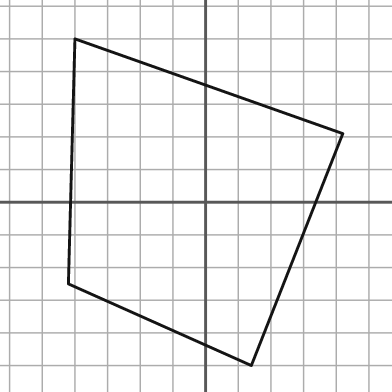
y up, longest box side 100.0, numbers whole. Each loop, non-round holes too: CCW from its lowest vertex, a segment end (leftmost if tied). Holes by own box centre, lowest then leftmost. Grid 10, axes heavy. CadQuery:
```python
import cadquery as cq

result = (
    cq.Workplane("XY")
    .moveTo(14.0, -50.0)
    .lineTo(42.0, 21.0)
    .lineTo(-40.0, 50.0)
    .lineTo(-42.0, -25.0)
    .close()
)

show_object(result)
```